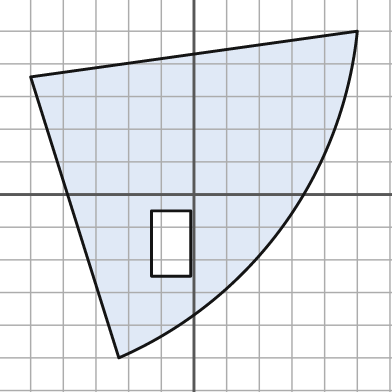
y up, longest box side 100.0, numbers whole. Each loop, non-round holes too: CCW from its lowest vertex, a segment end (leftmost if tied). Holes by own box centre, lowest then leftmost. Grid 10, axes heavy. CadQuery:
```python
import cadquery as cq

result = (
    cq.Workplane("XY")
    .moveTo(-23.0, -50.0)
    .threePointArc((27.0, -10.0), (50.0, 50.0))
    .lineTo(-50.0, 36.0)
    .close()
    .moveTo(-13.0, -25.0)
    .lineTo(-1.0, -25.0)
    .lineTo(-1.0, -5.0)
    .lineTo(-13.0, -5.0)
    .close()
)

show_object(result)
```